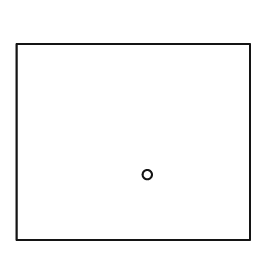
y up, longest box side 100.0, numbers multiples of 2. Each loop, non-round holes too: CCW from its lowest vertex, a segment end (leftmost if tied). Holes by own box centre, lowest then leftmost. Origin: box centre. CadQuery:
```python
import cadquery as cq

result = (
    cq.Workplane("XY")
    .moveTo(-50.0, -42.0)
    .lineTo(50.0, -42.0)
    .lineTo(50.0, 42.0)
    .lineTo(-50.0, 42.0)
    .close()
    .moveTo(6.0, -14.0)
    .circle(2.0)
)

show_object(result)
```